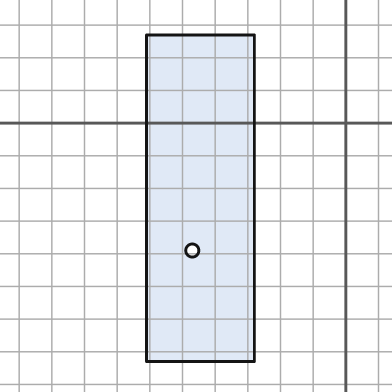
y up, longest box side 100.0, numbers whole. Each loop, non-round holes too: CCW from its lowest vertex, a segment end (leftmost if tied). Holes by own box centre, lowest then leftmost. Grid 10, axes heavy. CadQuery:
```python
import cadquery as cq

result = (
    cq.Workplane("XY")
    .moveTo(-61.0, -73.0)
    .lineTo(-28.0, -73.0)
    .lineTo(-28.0, 27.0)
    .lineTo(-61.0, 27.0)
    .close()
    .moveTo(-47.0, -39.0)
    .circle(2.0)
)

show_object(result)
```